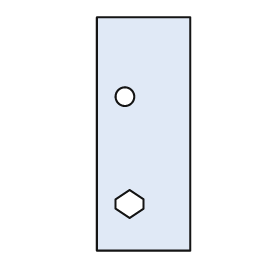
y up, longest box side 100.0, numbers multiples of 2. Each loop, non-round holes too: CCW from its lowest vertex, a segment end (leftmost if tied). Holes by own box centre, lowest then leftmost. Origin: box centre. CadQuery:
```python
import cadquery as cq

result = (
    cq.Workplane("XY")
    .moveTo(-20.0, -50.0)
    .lineTo(20.0, -50.0)
    .lineTo(20.0, 50.0)
    .lineTo(-20.0, 50.0)
    .close()
    .moveTo(-6.0, -36.0)
    .lineTo(0.0, -32.0)
    .lineTo(0.0, -28.0)
    .lineTo(-6.0, -24.0)
    .lineTo(-12.0, -28.0)
    .lineTo(-12.0, -32.0)
    .close()
    .moveTo(-8.0, 16.0)
    .circle(4.0)
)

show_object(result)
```